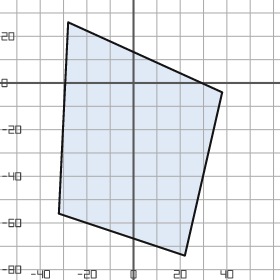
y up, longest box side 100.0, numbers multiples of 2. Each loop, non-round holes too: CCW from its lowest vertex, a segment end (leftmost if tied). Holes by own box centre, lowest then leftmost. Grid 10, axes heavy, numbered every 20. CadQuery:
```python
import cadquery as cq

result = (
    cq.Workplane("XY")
    .moveTo(22.0, -74.0)
    .lineTo(38.0, -4.0)
    .lineTo(-28.0, 26.0)
    .lineTo(-32.0, -56.0)
    .close()
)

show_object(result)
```